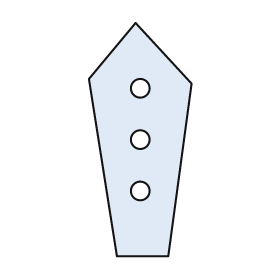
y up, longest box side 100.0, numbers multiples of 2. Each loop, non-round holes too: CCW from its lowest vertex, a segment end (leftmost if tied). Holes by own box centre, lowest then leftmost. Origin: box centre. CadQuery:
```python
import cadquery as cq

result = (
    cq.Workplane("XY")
    .moveTo(-10.0, -50.0)
    .lineTo(12.0, -50.0)
    .lineTo(22.0, 24.0)
    .lineTo(-2.0, 50.0)
    .lineTo(-22.0, 26.0)
    .close()
    .moveTo(0.0, -22.0)
    .circle(4.0)
    .moveTo(0.0, 0.0)
    .circle(4.0)
    .moveTo(0.0, 22.0)
    .circle(4.0)
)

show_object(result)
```